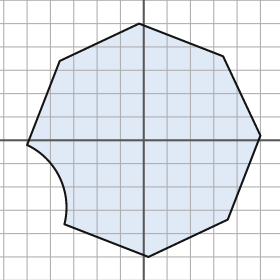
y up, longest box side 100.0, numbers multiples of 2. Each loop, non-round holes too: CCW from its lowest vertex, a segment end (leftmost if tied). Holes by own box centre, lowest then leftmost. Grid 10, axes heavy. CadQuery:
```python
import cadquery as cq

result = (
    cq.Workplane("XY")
    .moveTo(2.0, -50.0)
    .lineTo(36.0, -34.0)
    .lineTo(50.0, 2.0)
    .lineTo(34.0, 36.0)
    .lineTo(-2.0, 50.0)
    .lineTo(-36.0, 34.0)
    .lineTo(-50.0, -2.0)
    .threePointArc((-36.0, -16.0), (-34.0, -36.0))
    .close()
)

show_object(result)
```